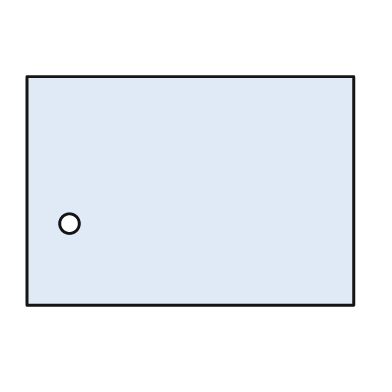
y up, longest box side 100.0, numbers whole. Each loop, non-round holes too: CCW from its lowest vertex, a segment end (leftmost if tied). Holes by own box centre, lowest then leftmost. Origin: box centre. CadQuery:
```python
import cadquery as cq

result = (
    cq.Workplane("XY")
    .moveTo(-50.0, -35.0)
    .lineTo(50.0, -35.0)
    .lineTo(50.0, 35.0)
    .lineTo(-50.0, 35.0)
    .close()
    .moveTo(-37.0, -10.0)
    .circle(3.0)
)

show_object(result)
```